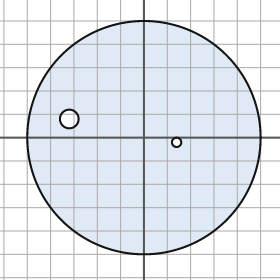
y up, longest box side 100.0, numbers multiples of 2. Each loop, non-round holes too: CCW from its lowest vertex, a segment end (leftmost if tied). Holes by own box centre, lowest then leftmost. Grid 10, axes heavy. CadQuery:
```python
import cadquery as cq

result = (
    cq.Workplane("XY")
    .moveTo(0.0, 0.0)
    .circle(50.0)
    .moveTo(14.0, -2.0)
    .circle(2.0)
    .moveTo(-32.0, 8.0)
    .circle(4.0)
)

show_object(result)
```